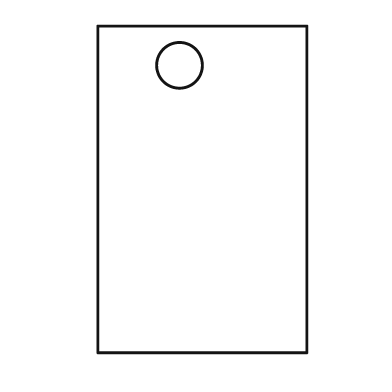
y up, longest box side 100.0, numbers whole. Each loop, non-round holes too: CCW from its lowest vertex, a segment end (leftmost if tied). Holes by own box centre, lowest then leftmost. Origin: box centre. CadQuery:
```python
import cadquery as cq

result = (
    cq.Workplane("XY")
    .moveTo(-32.0, -50.0)
    .lineTo(32.0, -50.0)
    .lineTo(32.0, 50.0)
    .lineTo(-32.0, 50.0)
    .close()
    .moveTo(-7.0, 38.0)
    .circle(7.0)
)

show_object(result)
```